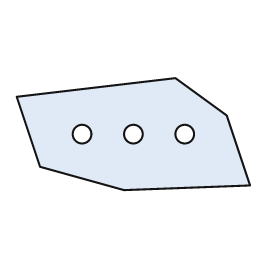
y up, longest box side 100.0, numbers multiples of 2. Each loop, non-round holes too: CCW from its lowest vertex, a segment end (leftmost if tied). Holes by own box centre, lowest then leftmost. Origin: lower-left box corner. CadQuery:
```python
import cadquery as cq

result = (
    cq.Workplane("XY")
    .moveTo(46.0, 0.0)
    .lineTo(100.0, 2.0)
    .lineTo(90.0, 32.0)
    .lineTo(68.0, 48.0)
    .lineTo(0.0, 40.0)
    .lineTo(10.0, 10.0)
    .close()
    .moveTo(28.0, 24.0)
    .circle(4.0)
    .moveTo(50.0, 24.0)
    .circle(4.0)
    .moveTo(72.0, 24.0)
    .circle(4.0)
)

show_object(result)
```